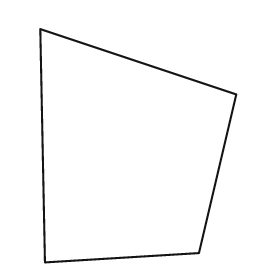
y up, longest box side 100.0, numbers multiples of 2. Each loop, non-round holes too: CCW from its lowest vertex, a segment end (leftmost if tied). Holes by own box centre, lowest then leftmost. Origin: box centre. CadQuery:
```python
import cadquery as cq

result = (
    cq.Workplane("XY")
    .moveTo(-40.0, -50.0)
    .lineTo(26.0, -46.0)
    .lineTo(42.0, 22.0)
    .lineTo(-42.0, 50.0)
    .close()
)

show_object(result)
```